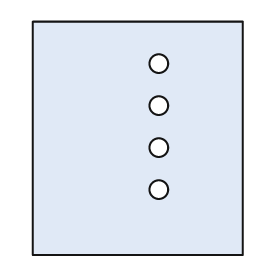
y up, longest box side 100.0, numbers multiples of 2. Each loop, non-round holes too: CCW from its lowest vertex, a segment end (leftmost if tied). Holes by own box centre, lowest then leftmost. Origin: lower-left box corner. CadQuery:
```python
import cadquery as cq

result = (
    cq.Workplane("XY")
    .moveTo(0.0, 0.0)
    .lineTo(90.0, 0.0)
    .lineTo(90.0, 100.0)
    .lineTo(0.0, 100.0)
    .close()
    .moveTo(54.0, 28.0)
    .circle(4.0)
    .moveTo(54.0, 46.0)
    .circle(4.0)
    .moveTo(54.0, 64.0)
    .circle(4.0)
    .moveTo(54.0, 82.0)
    .circle(4.0)
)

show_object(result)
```